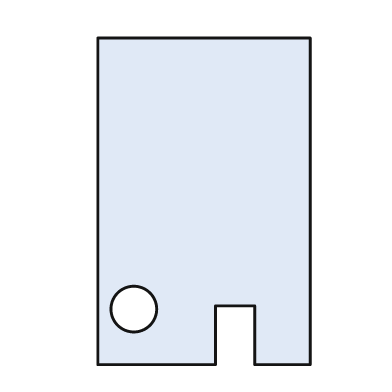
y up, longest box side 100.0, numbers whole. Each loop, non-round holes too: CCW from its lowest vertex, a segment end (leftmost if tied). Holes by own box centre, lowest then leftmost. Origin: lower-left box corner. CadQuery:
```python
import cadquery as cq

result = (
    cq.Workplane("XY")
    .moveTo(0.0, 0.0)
    .lineTo(36.0, 0.0)
    .lineTo(36.0, 18.0)
    .lineTo(48.0, 18.0)
    .lineTo(48.0, 0.0)
    .lineTo(65.0, 0.0)
    .lineTo(65.0, 100.0)
    .lineTo(0.0, 100.0)
    .close()
    .moveTo(11.0, 17.0)
    .circle(7.0)
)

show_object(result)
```